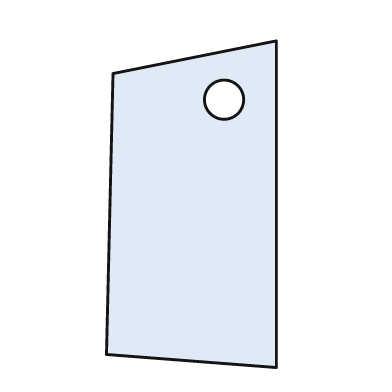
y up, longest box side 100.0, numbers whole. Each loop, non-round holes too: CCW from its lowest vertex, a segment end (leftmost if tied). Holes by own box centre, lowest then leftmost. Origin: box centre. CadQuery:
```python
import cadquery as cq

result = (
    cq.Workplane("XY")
    .moveTo(26.0, -50.0)
    .lineTo(26.0, 50.0)
    .lineTo(-24.0, 40.0)
    .lineTo(-26.0, -46.0)
    .close()
    .moveTo(10.0, 32.0)
    .circle(6.0)
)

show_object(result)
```